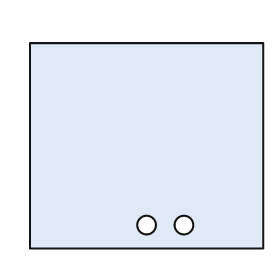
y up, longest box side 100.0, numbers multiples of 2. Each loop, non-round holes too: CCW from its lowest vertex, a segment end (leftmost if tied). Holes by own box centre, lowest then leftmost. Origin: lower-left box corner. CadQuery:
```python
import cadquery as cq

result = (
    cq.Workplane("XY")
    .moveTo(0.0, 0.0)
    .lineTo(100.0, 0.0)
    .lineTo(100.0, 88.0)
    .lineTo(0.0, 88.0)
    .close()
    .moveTo(50.0, 10.0)
    .circle(4.0)
    .moveTo(66.0, 10.0)
    .circle(4.0)
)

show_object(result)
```